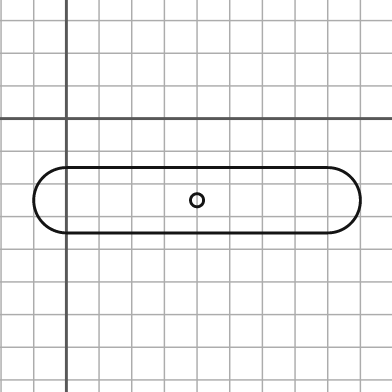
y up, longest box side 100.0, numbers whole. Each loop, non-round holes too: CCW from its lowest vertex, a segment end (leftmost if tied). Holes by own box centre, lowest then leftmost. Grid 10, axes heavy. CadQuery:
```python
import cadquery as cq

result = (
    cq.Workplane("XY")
    .moveTo(0.0, -35.0)
    .lineTo(80.0, -35.0)
    .threePointArc((90.0, -25.0), (80.0, -15.0))
    .lineTo(0.0, -15.0)
    .threePointArc((-10.0, -25.0), (0.0, -35.0))
    .close()
    .moveTo(40.0, -25.0)
    .circle(2.0)
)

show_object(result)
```